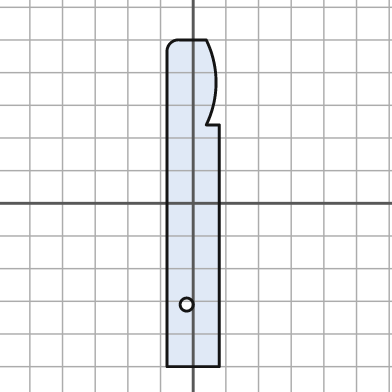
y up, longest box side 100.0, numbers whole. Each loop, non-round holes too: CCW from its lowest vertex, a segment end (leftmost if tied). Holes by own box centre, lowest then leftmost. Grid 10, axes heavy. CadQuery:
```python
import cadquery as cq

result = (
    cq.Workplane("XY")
    .moveTo(-8.0, -50.0)
    .lineTo(8.0, -50.0)
    .lineTo(8.0, 24.0)
    .lineTo(4.0, 24.0)
    .threePointArc((7.0, 37.0), (4.0, 50.0))
    .lineTo(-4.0, 50.0)
    .threePointArc((-7.0, 49.0), (-8.0, 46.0))
    .close()
    .moveTo(-2.0, -31.0)
    .circle(2.0)
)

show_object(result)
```